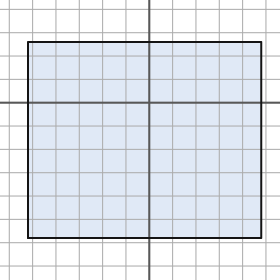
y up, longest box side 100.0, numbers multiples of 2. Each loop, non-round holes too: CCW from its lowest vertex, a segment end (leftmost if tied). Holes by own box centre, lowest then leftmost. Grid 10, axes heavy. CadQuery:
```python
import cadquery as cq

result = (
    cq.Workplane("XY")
    .moveTo(-52.0, -58.0)
    .lineTo(48.0, -58.0)
    .lineTo(48.0, 26.0)
    .lineTo(-52.0, 26.0)
    .close()
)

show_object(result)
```